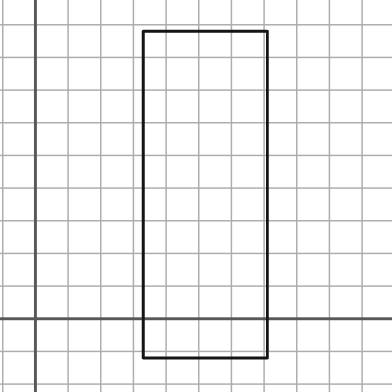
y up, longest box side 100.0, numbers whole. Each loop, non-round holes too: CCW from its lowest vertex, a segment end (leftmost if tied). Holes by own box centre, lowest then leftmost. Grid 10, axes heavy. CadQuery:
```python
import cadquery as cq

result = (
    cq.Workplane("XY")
    .moveTo(33.0, -12.0)
    .lineTo(71.0, -12.0)
    .lineTo(71.0, 88.0)
    .lineTo(33.0, 88.0)
    .close()
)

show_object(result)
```